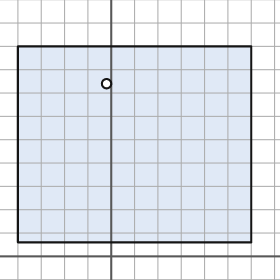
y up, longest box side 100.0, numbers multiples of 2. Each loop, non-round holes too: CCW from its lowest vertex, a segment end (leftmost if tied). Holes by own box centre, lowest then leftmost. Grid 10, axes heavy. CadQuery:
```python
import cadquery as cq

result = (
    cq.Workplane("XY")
    .moveTo(-40.0, 6.0)
    .lineTo(60.0, 6.0)
    .lineTo(60.0, 90.0)
    .lineTo(-40.0, 90.0)
    .close()
    .moveTo(-2.0, 74.0)
    .circle(2.0)
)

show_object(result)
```